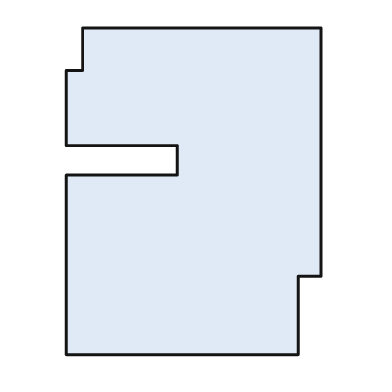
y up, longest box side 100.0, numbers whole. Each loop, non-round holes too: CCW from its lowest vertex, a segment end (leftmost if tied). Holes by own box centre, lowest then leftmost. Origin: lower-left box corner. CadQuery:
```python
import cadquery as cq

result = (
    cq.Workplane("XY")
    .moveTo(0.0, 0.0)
    .lineTo(71.0, 0.0)
    .lineTo(71.0, 24.0)
    .lineTo(78.0, 24.0)
    .lineTo(78.0, 100.0)
    .lineTo(5.0, 100.0)
    .lineTo(5.0, 87.0)
    .lineTo(0.0, 87.0)
    .lineTo(0.0, 64.0)
    .lineTo(34.0, 64.0)
    .lineTo(34.0, 55.0)
    .lineTo(0.0, 55.0)
    .close()
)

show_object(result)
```